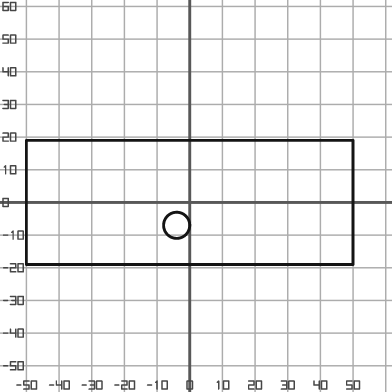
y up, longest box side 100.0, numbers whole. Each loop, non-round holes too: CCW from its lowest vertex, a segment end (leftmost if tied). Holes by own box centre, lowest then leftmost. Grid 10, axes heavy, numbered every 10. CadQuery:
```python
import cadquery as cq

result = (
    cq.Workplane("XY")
    .moveTo(-50.0, -19.0)
    .lineTo(50.0, -19.0)
    .lineTo(50.0, 19.0)
    .lineTo(-50.0, 19.0)
    .close()
    .moveTo(-4.0, -7.0)
    .circle(4.0)
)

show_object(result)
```